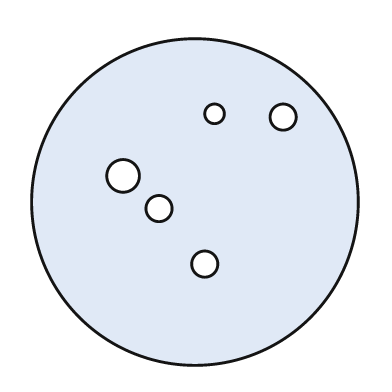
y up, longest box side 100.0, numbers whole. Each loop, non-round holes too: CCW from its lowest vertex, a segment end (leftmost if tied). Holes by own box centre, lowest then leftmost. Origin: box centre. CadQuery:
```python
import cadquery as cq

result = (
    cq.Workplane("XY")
    .moveTo(0.0, 0.0)
    .circle(50.0)
    .moveTo(3.0, -19.0)
    .circle(4.0)
    .moveTo(-11.0, -2.0)
    .circle(4.0)
    .moveTo(-22.0, 8.0)
    .circle(5.0)
    .moveTo(27.0, 26.0)
    .circle(4.0)
    .moveTo(6.0, 27.0)
    .circle(3.0)
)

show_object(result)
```